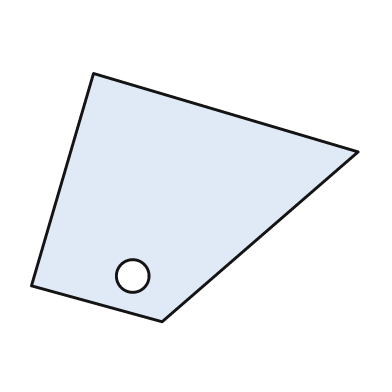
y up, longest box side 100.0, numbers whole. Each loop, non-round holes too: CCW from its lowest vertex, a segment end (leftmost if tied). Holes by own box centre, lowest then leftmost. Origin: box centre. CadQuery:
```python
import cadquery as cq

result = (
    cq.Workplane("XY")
    .moveTo(-10.0, -38.0)
    .lineTo(50.0, 14.0)
    .lineTo(-31.0, 38.0)
    .lineTo(-50.0, -27.0)
    .close()
    .moveTo(-19.0, -24.0)
    .circle(5.0)
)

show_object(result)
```